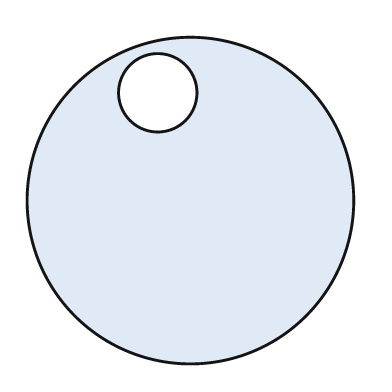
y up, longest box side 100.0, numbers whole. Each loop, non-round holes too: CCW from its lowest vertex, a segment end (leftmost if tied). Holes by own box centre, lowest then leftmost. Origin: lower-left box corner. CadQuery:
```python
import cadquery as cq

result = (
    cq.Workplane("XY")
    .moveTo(50.0, 50.0)
    .circle(50.0)
    .moveTo(40.0, 83.0)
    .circle(12.0)
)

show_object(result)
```